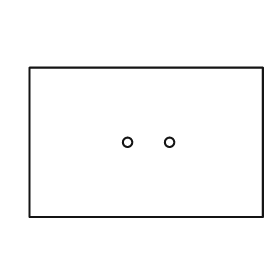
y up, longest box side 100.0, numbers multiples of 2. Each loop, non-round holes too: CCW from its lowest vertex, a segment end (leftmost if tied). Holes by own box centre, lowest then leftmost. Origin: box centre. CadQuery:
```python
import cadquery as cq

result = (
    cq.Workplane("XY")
    .moveTo(-50.0, -32.0)
    .lineTo(50.0, -32.0)
    .lineTo(50.0, 32.0)
    .lineTo(-50.0, 32.0)
    .close()
    .moveTo(-8.0, 0.0)
    .circle(2.0)
    .moveTo(10.0, 0.0)
    .circle(2.0)
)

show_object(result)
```